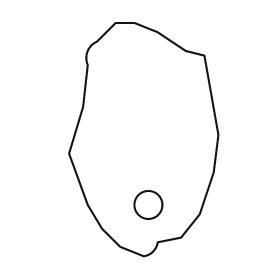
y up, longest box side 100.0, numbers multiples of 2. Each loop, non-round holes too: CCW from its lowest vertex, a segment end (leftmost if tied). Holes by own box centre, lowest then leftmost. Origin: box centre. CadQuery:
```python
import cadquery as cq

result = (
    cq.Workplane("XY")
    .moveTo(0.0, -50.0)
    .threePointArc((4.0, -48.0), (6.0, -44.0))
    .lineTo(16.0, -42.0)
    .lineTo(24.0, -32.0)
    .lineTo(30.0, -14.0)
    .lineTo(32.0, 2.0)
    .lineTo(26.0, 36.0)
    .lineTo(18.0, 38.0)
    .lineTo(6.0, 46.0)
    .lineTo(-4.0, 50.0)
    .lineTo(-12.0, 50.0)
    .lineTo(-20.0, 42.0)
    .threePointArc((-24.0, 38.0), (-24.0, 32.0))
    .lineTo(-26.0, 14.0)
    .lineTo(-32.0, -6.0)
    .lineTo(-24.0, -28.0)
    .lineTo(-18.0, -38.0)
    .lineTo(-10.0, -46.0)
    .close()
    .moveTo(2.0, -28.0)
    .circle(6.0)
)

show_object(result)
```